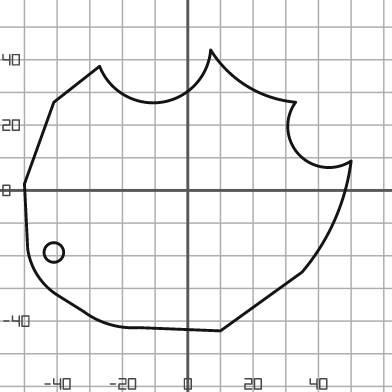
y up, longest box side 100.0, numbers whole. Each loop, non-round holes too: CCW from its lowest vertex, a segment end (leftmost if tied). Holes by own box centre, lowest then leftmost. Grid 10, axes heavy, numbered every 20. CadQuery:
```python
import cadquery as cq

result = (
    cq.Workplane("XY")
    .moveTo(10.0, -43.0)
    .lineTo(35.0, -25.0)
    .threePointArc((45.0, -9.0), (50.0, 9.0))
    .threePointArc((34.0, 11.0), (33.0, 27.0))
    .threePointArc((18.0, 32.0), (7.0, 43.0))
    .threePointArc((-8.0, 27.0), (-27.0, 38.0))
    .lineTo(-41.0, 27.0)
    .lineTo(-50.0, 2.0)
    .lineTo(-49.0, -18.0)
    .threePointArc((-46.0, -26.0), (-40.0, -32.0))
    .lineTo(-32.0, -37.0)
    .threePointArc((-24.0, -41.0), (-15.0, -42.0))
    .close()
    .moveTo(-41.0, -19.0)
    .circle(3.0)
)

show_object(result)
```